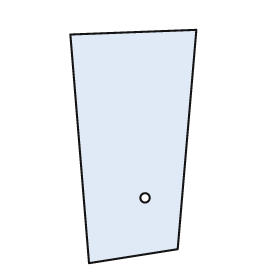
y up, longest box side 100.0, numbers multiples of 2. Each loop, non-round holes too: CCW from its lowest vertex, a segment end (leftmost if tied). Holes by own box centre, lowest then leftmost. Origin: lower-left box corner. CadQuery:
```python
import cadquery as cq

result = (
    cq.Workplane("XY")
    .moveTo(8.0, 0.0)
    .lineTo(46.0, 6.0)
    .lineTo(54.0, 100.0)
    .lineTo(0.0, 98.0)
    .close()
    .moveTo(32.0, 28.0)
    .circle(2.0)
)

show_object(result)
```